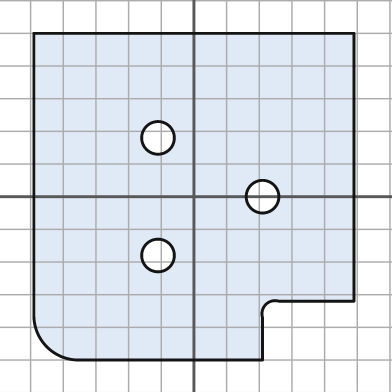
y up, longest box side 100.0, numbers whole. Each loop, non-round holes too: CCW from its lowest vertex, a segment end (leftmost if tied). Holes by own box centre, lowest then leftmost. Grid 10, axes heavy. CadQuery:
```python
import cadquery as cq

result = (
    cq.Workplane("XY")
    .moveTo(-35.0, -50.0)
    .lineTo(21.0, -50.0)
    .lineTo(21.0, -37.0)
    .threePointArc((22.0, -33.0), (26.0, -32.0))
    .lineTo(49.0, -32.0)
    .lineTo(49.0, 50.0)
    .lineTo(-49.0, 50.0)
    .lineTo(-49.0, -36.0)
    .threePointArc((-45.0, -46.0), (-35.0, -50.0))
    .close()
    .moveTo(-11.0, -18.0)
    .circle(5.0)
    .moveTo(21.0, 0.0)
    .circle(5.0)
    .moveTo(-11.0, 18.0)
    .circle(5.0)
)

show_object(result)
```